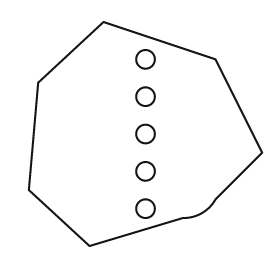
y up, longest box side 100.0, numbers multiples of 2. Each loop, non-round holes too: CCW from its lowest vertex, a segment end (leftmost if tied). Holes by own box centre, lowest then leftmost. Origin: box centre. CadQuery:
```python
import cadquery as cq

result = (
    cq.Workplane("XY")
    .moveTo(-24.0, -48.0)
    .lineTo(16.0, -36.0)
    .threePointArc((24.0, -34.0), (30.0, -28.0))
    .lineTo(50.0, -8.0)
    .lineTo(30.0, 32.0)
    .lineTo(-18.0, 48.0)
    .lineTo(-46.0, 22.0)
    .lineTo(-50.0, -24.0)
    .close()
    .moveTo(0.0, -32.0)
    .circle(4.0)
    .moveTo(0.0, -16.0)
    .circle(4.0)
    .moveTo(0.0, 0.0)
    .circle(4.0)
    .moveTo(0.0, 16.0)
    .circle(4.0)
    .moveTo(0.0, 32.0)
    .circle(4.0)
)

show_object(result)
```